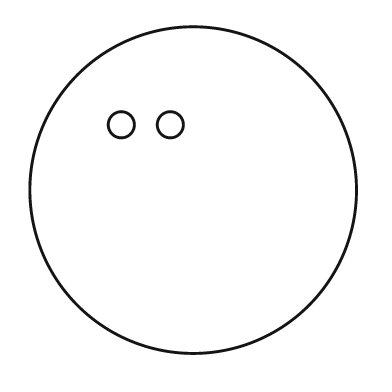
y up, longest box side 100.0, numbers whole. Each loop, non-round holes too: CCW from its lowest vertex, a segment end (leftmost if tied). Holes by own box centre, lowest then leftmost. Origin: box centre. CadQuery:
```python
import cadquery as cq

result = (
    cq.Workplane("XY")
    .moveTo(0.0, 0.0)
    .circle(50.0)
    .moveTo(-22.0, 20.0)
    .circle(4.0)
    .moveTo(-7.0, 20.0)
    .circle(4.0)
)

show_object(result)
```